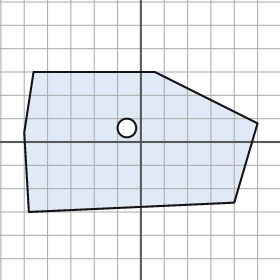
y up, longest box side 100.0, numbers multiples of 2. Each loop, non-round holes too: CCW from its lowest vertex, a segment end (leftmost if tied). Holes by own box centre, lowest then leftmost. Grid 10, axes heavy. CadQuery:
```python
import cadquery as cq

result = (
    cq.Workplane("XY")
    .moveTo(-48.0, -30.0)
    .lineTo(40.0, -26.0)
    .lineTo(50.0, 8.0)
    .lineTo(6.0, 30.0)
    .lineTo(-46.0, 30.0)
    .lineTo(-50.0, 4.0)
    .close()
    .moveTo(-6.0, 6.0)
    .circle(4.0)
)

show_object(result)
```